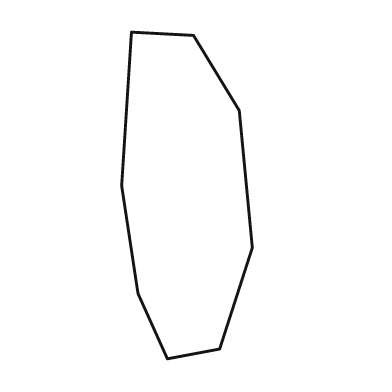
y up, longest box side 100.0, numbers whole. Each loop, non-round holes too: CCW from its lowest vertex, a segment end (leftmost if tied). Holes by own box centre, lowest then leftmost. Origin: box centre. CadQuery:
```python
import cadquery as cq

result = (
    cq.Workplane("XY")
    .moveTo(-6.0, -50.0)
    .lineTo(10.0, -47.0)
    .lineTo(20.0, -16.0)
    .lineTo(16.0, 26.0)
    .lineTo(2.0, 49.0)
    .lineTo(-17.0, 50.0)
    .lineTo(-20.0, 3.0)
    .lineTo(-15.0, -30.0)
    .close()
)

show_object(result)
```